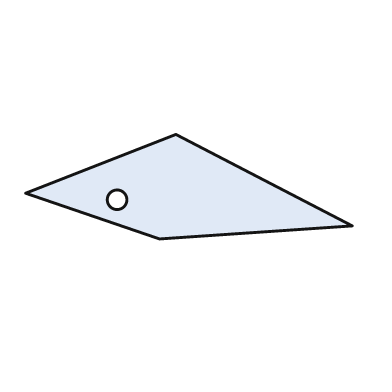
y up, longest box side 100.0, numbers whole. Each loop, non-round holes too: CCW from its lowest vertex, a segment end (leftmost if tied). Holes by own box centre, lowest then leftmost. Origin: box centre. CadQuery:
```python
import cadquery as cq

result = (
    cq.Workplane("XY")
    .moveTo(-9.0, -16.0)
    .lineTo(50.0, -12.0)
    .lineTo(-4.0, 16.0)
    .lineTo(-50.0, -2.0)
    .close()
    .moveTo(-22.0, -4.0)
    .circle(3.0)
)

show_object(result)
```